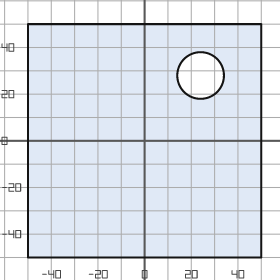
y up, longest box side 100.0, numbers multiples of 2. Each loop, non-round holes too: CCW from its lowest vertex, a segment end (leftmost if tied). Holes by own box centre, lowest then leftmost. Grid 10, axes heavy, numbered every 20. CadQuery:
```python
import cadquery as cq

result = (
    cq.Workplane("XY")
    .moveTo(-50.0, -50.0)
    .lineTo(50.0, -50.0)
    .lineTo(50.0, 50.0)
    .lineTo(-50.0, 50.0)
    .close()
    .moveTo(24.0, 28.0)
    .circle(10.0)
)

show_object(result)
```